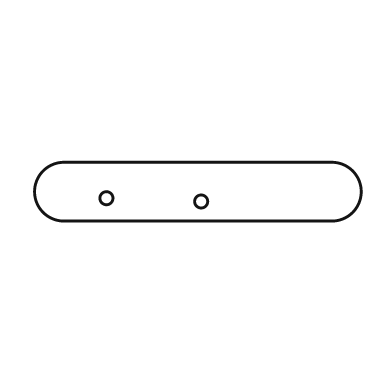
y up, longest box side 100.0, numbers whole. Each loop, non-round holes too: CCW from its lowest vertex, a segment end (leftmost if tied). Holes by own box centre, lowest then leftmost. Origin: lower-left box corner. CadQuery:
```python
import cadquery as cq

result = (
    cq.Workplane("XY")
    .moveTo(9.0, 0.0)
    .lineTo(91.0, 0.0)
    .threePointArc((100.0, 9.0), (91.0, 18.0))
    .lineTo(9.0, 18.0)
    .threePointArc((0.0, 9.0), (9.0, 0.0))
    .close()
    .moveTo(51.0, 6.0)
    .circle(2.0)
    .moveTo(22.0, 7.0)
    .circle(2.0)
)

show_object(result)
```